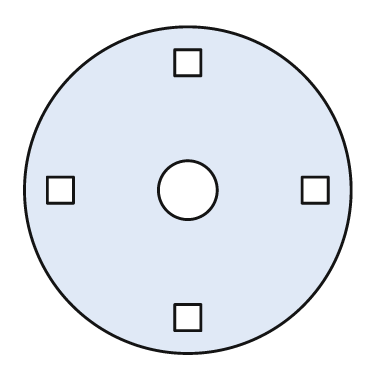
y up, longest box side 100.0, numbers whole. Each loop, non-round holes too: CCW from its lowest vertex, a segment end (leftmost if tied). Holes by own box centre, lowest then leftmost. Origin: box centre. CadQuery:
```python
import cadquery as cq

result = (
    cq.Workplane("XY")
    .moveTo(0.0, 0.0)
    .circle(50.0)
    .moveTo(-4.0, -43.0)
    .lineTo(4.0, -43.0)
    .lineTo(4.0, -35.0)
    .lineTo(-4.0, -35.0)
    .close()
    .moveTo(-43.0, -4.0)
    .lineTo(-35.0, -4.0)
    .lineTo(-35.0, 4.0)
    .lineTo(-43.0, 4.0)
    .close()
    .moveTo(0.0, 0.0)
    .circle(9.0)
    .moveTo(35.0, -4.0)
    .lineTo(43.0, -4.0)
    .lineTo(43.0, 4.0)
    .lineTo(35.0, 4.0)
    .close()
    .moveTo(-4.0, 35.0)
    .lineTo(4.0, 35.0)
    .lineTo(4.0, 43.0)
    .lineTo(-4.0, 43.0)
    .close()
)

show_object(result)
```